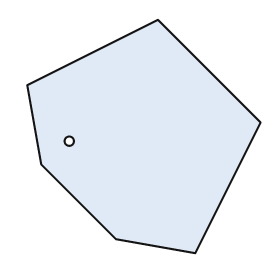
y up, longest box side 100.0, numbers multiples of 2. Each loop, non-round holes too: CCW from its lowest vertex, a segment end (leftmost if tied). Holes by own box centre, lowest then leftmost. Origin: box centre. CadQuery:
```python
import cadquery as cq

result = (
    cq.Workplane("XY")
    .moveTo(22.0, -50.0)
    .lineTo(50.0, 6.0)
    .lineTo(6.0, 50.0)
    .lineTo(-50.0, 22.0)
    .lineTo(-44.0, -12.0)
    .lineTo(-12.0, -44.0)
    .close()
    .moveTo(-32.0, -2.0)
    .circle(2.0)
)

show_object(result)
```